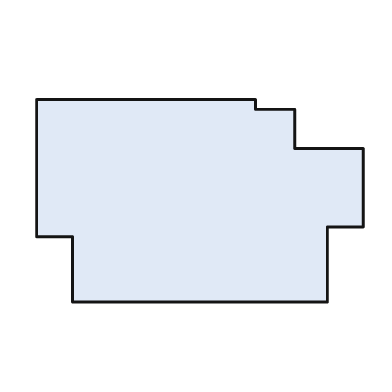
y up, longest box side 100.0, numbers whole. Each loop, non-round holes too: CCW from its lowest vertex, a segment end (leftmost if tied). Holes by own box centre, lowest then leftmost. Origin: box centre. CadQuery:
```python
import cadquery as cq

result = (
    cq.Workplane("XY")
    .moveTo(-39.0, -31.0)
    .lineTo(39.0, -31.0)
    .lineTo(39.0, -8.0)
    .lineTo(50.0, -8.0)
    .lineTo(50.0, 16.0)
    .lineTo(29.0, 16.0)
    .lineTo(29.0, 28.0)
    .lineTo(17.0, 28.0)
    .lineTo(17.0, 31.0)
    .lineTo(-50.0, 31.0)
    .lineTo(-50.0, -11.0)
    .lineTo(-39.0, -11.0)
    .close()
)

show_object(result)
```